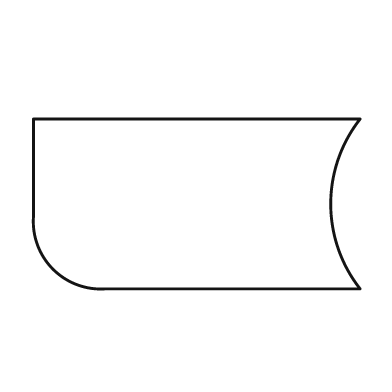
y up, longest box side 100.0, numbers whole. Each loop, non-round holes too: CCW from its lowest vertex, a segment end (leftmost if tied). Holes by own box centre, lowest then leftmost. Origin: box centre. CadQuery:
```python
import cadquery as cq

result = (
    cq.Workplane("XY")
    .moveTo(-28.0, -26.0)
    .lineTo(50.0, -26.0)
    .threePointArc((41.0, 0.0), (50.0, 26.0))
    .lineTo(-50.0, 26.0)
    .lineTo(-50.0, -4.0)
    .threePointArc((-44.0, -20.0), (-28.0, -26.0))
    .close()
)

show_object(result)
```